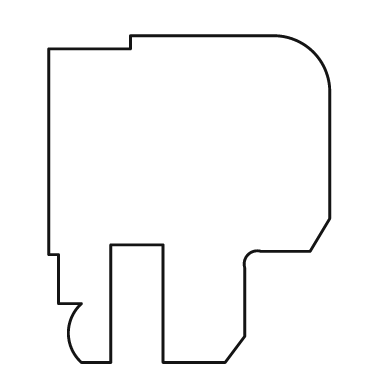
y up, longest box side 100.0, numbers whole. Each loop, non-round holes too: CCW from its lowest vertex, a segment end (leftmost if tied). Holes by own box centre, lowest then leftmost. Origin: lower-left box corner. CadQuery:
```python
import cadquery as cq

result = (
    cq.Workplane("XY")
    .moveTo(10.0, 0.0)
    .lineTo(19.0, 0.0)
    .lineTo(19.0, 36.0)
    .lineTo(35.0, 36.0)
    .lineTo(35.0, 0.0)
    .lineTo(54.0, 0.0)
    .lineTo(60.0, 8.0)
    .lineTo(60.0, 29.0)
    .threePointArc((61.0, 33.0), (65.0, 34.0))
    .lineTo(80.0, 34.0)
    .lineTo(86.0, 44.0)
    .lineTo(86.0, 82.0)
    .threePointArc((81.0, 95.0), (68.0, 100.0))
    .lineTo(25.0, 100.0)
    .lineTo(25.0, 96.0)
    .lineTo(0.0, 96.0)
    .lineTo(0.0, 33.0)
    .lineTo(3.0, 33.0)
    .lineTo(3.0, 18.0)
    .lineTo(10.0, 18.0)
    .threePointArc((6.0, 9.0), (10.0, 0.0))
    .close()
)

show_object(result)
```